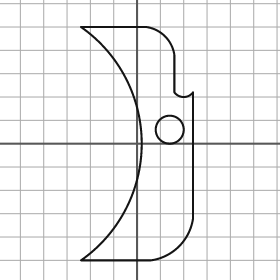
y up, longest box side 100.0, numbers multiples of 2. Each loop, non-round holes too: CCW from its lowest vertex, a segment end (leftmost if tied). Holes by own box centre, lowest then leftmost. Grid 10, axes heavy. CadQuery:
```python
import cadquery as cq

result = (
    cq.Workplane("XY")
    .moveTo(-24.0, -50.0)
    .lineTo(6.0, -50.0)
    .threePointArc((18.0, -44.0), (24.0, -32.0))
    .lineTo(24.0, 22.0)
    .threePointArc((20.0, 20.0), (16.0, 22.0))
    .lineTo(16.0, 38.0)
    .threePointArc((12.0, 46.0), (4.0, 50.0))
    .lineTo(-24.0, 50.0)
    .threePointArc((2.0, 0.0), (-24.0, -50.0))
    .close()
    .moveTo(14.0, 6.0)
    .circle(6.0)
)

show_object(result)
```